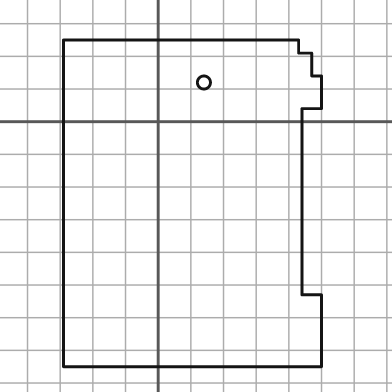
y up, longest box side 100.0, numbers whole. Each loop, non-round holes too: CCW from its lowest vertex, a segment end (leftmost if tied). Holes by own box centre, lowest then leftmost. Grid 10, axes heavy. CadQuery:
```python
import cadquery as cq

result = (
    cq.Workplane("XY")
    .moveTo(-29.0, -75.0)
    .lineTo(50.0, -75.0)
    .lineTo(50.0, -53.0)
    .lineTo(44.0, -53.0)
    .lineTo(44.0, 4.0)
    .lineTo(50.0, 4.0)
    .lineTo(50.0, 14.0)
    .lineTo(47.0, 14.0)
    .lineTo(47.0, 21.0)
    .lineTo(43.0, 21.0)
    .lineTo(43.0, 25.0)
    .lineTo(-29.0, 25.0)
    .close()
    .moveTo(14.0, 12.0)
    .circle(2.0)
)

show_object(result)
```